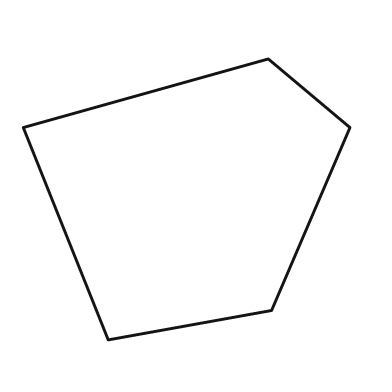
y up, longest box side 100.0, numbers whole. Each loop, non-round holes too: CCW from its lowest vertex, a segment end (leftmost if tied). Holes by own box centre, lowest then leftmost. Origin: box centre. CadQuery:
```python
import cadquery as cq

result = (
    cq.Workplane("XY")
    .moveTo(-24.0, -43.0)
    .lineTo(26.0, -34.0)
    .lineTo(50.0, 22.0)
    .lineTo(25.0, 43.0)
    .lineTo(-50.0, 22.0)
    .close()
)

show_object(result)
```